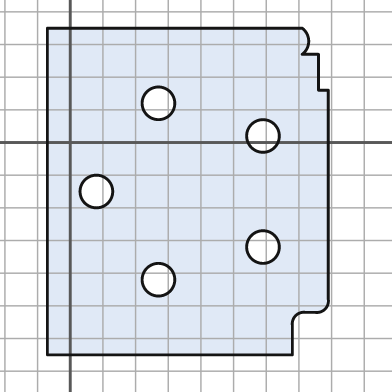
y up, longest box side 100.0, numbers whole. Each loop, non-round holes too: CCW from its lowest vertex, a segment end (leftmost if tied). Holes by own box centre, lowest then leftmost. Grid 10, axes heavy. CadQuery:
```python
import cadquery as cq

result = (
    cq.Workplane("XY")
    .moveTo(-7.0, -65.0)
    .lineTo(68.0, -65.0)
    .lineTo(68.0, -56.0)
    .threePointArc((69.0, -53.0), (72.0, -52.0))
    .lineTo(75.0, -52.0)
    .threePointArc((78.0, -51.0), (79.0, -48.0))
    .lineTo(79.0, 16.0)
    .lineTo(76.0, 16.0)
    .lineTo(76.0, 27.0)
    .lineTo(71.0, 27.0)
    .threePointArc((73.0, 31.0), (71.0, 35.0))
    .lineTo(-7.0, 35.0)
    .close()
    .moveTo(27.0, -42.0)
    .circle(5.0)
    .moveTo(59.0, -32.0)
    .circle(5.0)
    .moveTo(8.0, -15.0)
    .circle(5.0)
    .moveTo(59.0, 2.0)
    .circle(5.0)
    .moveTo(27.0, 12.0)
    .circle(5.0)
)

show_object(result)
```